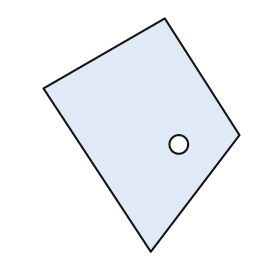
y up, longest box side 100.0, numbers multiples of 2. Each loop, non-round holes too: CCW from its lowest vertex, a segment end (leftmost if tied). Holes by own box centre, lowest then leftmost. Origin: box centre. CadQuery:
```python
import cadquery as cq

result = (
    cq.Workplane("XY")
    .moveTo(4.0, -50.0)
    .lineTo(42.0, 0.0)
    .lineTo(10.0, 50.0)
    .lineTo(-42.0, 20.0)
    .close()
    .moveTo(16.0, -4.0)
    .circle(4.0)
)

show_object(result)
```